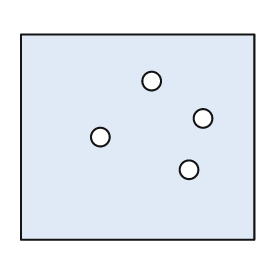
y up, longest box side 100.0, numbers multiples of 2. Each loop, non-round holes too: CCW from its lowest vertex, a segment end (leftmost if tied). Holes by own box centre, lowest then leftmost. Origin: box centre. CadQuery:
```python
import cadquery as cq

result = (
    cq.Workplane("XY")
    .moveTo(-50.0, -44.0)
    .lineTo(50.0, -44.0)
    .lineTo(50.0, 44.0)
    .lineTo(-50.0, 44.0)
    .close()
    .moveTo(22.0, -14.0)
    .circle(4.0)
    .moveTo(-16.0, 0.0)
    .circle(4.0)
    .moveTo(28.0, 8.0)
    .circle(4.0)
    .moveTo(6.0, 24.0)
    .circle(4.0)
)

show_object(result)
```